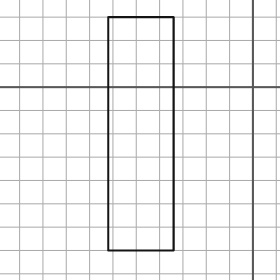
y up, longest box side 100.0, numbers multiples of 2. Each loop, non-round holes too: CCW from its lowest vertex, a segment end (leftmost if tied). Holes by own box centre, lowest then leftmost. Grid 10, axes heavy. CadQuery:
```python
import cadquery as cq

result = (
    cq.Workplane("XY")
    .moveTo(-62.0, -70.0)
    .lineTo(-34.0, -70.0)
    .lineTo(-34.0, 30.0)
    .lineTo(-62.0, 30.0)
    .close()
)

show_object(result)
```